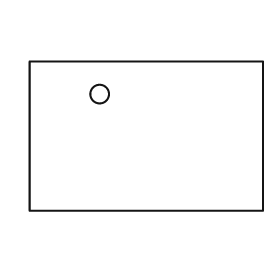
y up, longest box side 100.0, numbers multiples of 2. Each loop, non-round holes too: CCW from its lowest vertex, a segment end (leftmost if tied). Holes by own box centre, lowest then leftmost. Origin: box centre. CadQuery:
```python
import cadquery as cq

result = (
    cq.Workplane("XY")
    .moveTo(-50.0, -32.0)
    .lineTo(50.0, -32.0)
    .lineTo(50.0, 32.0)
    .lineTo(-50.0, 32.0)
    .close()
    .moveTo(-20.0, 18.0)
    .circle(4.0)
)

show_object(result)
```